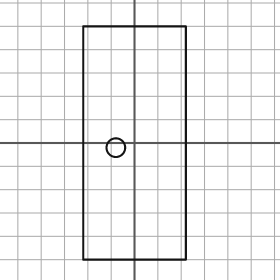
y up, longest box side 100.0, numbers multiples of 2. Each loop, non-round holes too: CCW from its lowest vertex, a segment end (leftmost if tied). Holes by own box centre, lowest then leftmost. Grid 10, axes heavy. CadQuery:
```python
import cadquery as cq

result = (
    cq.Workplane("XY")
    .moveTo(-22.0, -50.0)
    .lineTo(22.0, -50.0)
    .lineTo(22.0, 50.0)
    .lineTo(-22.0, 50.0)
    .close()
    .moveTo(-8.0, -2.0)
    .circle(4.0)
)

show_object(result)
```